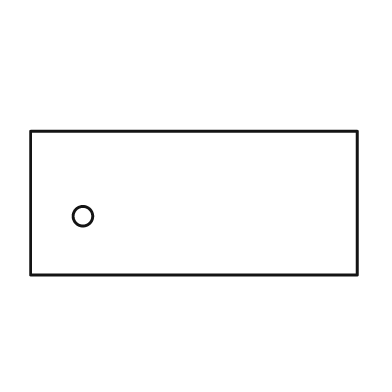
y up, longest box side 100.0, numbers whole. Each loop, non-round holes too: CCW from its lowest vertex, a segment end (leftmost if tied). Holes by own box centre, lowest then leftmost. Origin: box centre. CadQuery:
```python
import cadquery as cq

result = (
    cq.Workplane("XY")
    .moveTo(-50.0, -22.0)
    .lineTo(50.0, -22.0)
    .lineTo(50.0, 22.0)
    .lineTo(-50.0, 22.0)
    .close()
    .moveTo(-34.0, -4.0)
    .circle(3.0)
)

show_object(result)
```